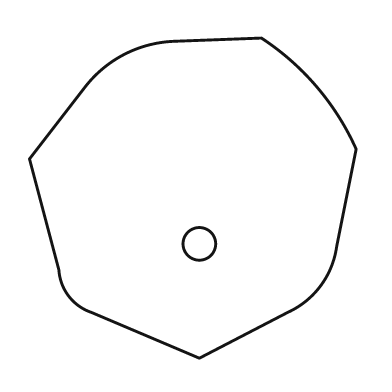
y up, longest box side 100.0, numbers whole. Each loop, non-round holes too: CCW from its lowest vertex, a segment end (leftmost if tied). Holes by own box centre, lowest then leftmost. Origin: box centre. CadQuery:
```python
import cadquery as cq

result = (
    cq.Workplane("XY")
    .moveTo(2.0, -49.0)
    .lineTo(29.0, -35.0)
    .threePointArc((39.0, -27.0), (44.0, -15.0))
    .lineTo(50.0, 15.0)
    .threePointArc((38.0, 34.0), (21.0, 49.0))
    .lineTo(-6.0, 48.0)
    .threePointArc((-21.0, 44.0), (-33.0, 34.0))
    .lineTo(-50.0, 12.0)
    .lineTo(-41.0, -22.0)
    .threePointArc((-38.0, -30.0), (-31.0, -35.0))
    .close()
    .moveTo(2.0, -14.0)
    .circle(5.0)
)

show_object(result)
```